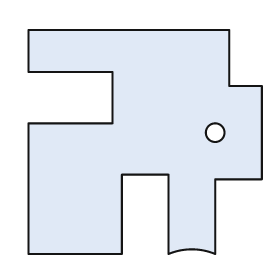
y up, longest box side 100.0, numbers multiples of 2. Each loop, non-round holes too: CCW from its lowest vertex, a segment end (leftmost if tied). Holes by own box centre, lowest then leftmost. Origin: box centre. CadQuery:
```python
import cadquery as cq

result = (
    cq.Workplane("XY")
    .moveTo(-50.0, -48.0)
    .lineTo(-10.0, -48.0)
    .lineTo(-10.0, -14.0)
    .lineTo(10.0, -14.0)
    .lineTo(10.0, -48.0)
    .threePointArc((20.0, -46.0), (30.0, -48.0))
    .lineTo(30.0, -16.0)
    .lineTo(50.0, -16.0)
    .lineTo(50.0, 24.0)
    .lineTo(36.0, 24.0)
    .lineTo(36.0, 48.0)
    .lineTo(-50.0, 48.0)
    .lineTo(-50.0, 30.0)
    .lineTo(-14.0, 30.0)
    .lineTo(-14.0, 8.0)
    .lineTo(-50.0, 8.0)
    .close()
    .moveTo(30.0, 4.0)
    .circle(4.0)
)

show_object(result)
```